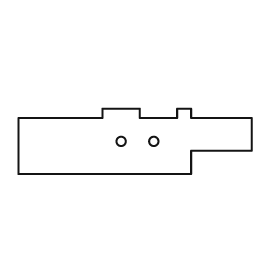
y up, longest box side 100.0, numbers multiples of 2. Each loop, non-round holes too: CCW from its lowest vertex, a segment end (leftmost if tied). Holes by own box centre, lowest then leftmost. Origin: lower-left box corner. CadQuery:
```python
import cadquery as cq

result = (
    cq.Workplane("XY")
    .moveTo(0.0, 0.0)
    .lineTo(74.0, 0.0)
    .lineTo(74.0, 10.0)
    .lineTo(100.0, 10.0)
    .lineTo(100.0, 24.0)
    .lineTo(74.0, 24.0)
    .lineTo(74.0, 28.0)
    .lineTo(68.0, 28.0)
    .lineTo(68.0, 24.0)
    .lineTo(52.0, 24.0)
    .lineTo(52.0, 28.0)
    .lineTo(36.0, 28.0)
    .lineTo(36.0, 24.0)
    .lineTo(0.0, 24.0)
    .close()
    .moveTo(44.0, 14.0)
    .circle(2.0)
    .moveTo(58.0, 14.0)
    .circle(2.0)
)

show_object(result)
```